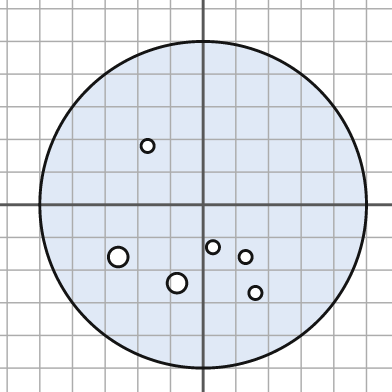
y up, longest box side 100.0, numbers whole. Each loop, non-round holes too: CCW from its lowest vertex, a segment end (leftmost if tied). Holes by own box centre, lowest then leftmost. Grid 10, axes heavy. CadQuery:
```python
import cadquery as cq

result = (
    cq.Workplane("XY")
    .moveTo(0.0, 0.0)
    .circle(50.0)
    .moveTo(16.0, -27.0)
    .circle(2.0)
    .moveTo(-8.0, -24.0)
    .circle(3.0)
    .moveTo(-26.0, -16.0)
    .circle(3.0)
    .moveTo(13.0, -16.0)
    .circle(2.0)
    .moveTo(3.0, -13.0)
    .circle(2.0)
    .moveTo(-17.0, 18.0)
    .circle(2.0)
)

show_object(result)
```